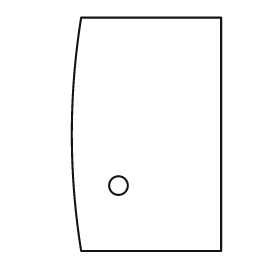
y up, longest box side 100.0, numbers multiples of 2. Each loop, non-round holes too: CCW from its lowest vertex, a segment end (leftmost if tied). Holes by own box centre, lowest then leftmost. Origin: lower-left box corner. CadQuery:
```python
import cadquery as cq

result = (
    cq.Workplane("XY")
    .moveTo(4.0, 0.0)
    .lineTo(64.0, 0.0)
    .lineTo(64.0, 100.0)
    .lineTo(4.0, 100.0)
    .threePointArc((0.0, 50.0), (4.0, 0.0))
    .close()
    .moveTo(20.0, 28.0)
    .circle(4.0)
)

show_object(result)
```